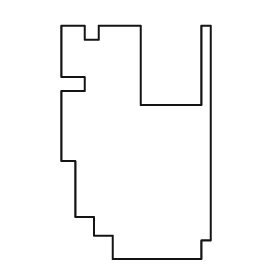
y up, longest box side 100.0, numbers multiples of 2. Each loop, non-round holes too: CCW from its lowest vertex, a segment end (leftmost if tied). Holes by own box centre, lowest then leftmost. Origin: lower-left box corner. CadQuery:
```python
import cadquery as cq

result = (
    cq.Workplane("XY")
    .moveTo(22.0, 0.0)
    .lineTo(60.0, 0.0)
    .lineTo(60.0, 8.0)
    .lineTo(64.0, 8.0)
    .lineTo(64.0, 100.0)
    .lineTo(60.0, 100.0)
    .lineTo(60.0, 66.0)
    .lineTo(34.0, 66.0)
    .lineTo(34.0, 100.0)
    .lineTo(16.0, 100.0)
    .lineTo(16.0, 94.0)
    .lineTo(10.0, 94.0)
    .lineTo(10.0, 100.0)
    .lineTo(0.0, 100.0)
    .lineTo(0.0, 78.0)
    .lineTo(10.0, 78.0)
    .lineTo(10.0, 72.0)
    .lineTo(0.0, 72.0)
    .lineTo(0.0, 42.0)
    .lineTo(6.0, 42.0)
    .lineTo(6.0, 18.0)
    .lineTo(14.0, 18.0)
    .lineTo(14.0, 10.0)
    .lineTo(22.0, 10.0)
    .close()
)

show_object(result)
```